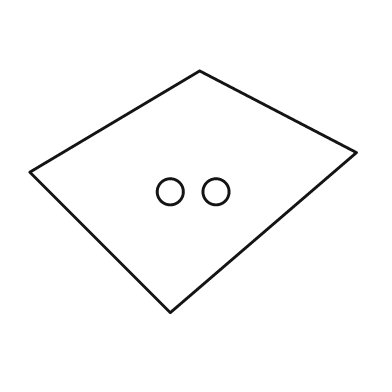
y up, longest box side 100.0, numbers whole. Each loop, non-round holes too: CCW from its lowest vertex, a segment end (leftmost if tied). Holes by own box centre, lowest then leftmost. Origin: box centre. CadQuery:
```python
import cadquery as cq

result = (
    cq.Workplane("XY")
    .moveTo(-7.0, -37.0)
    .lineTo(50.0, 12.0)
    .lineTo(2.0, 37.0)
    .lineTo(-50.0, 6.0)
    .close()
    .moveTo(-7.0, 0.0)
    .circle(4.0)
    .moveTo(7.0, 0.0)
    .circle(4.0)
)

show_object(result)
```